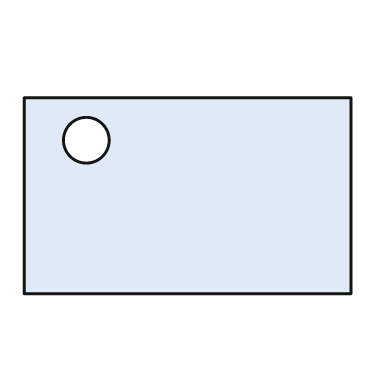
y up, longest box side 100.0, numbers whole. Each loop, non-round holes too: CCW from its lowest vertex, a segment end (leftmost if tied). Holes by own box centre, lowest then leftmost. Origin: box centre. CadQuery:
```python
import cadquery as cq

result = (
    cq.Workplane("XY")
    .moveTo(-50.0, -30.0)
    .lineTo(50.0, -30.0)
    .lineTo(50.0, 30.0)
    .lineTo(-50.0, 30.0)
    .close()
    .moveTo(-31.0, 17.0)
    .circle(7.0)
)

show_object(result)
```